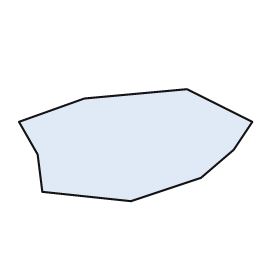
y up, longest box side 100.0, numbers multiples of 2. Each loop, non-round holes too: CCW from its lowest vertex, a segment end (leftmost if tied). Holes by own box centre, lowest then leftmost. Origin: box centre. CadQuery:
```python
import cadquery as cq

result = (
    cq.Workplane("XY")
    .moveTo(-2.0, -24.0)
    .lineTo(28.0, -14.0)
    .lineTo(42.0, -2.0)
    .lineTo(50.0, 10.0)
    .lineTo(22.0, 24.0)
    .lineTo(-22.0, 20.0)
    .lineTo(-50.0, 10.0)
    .lineTo(-42.0, -4.0)
    .lineTo(-40.0, -20.0)
    .close()
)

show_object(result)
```